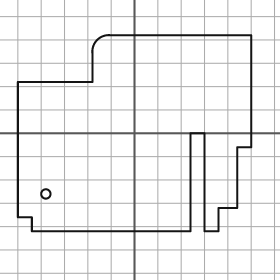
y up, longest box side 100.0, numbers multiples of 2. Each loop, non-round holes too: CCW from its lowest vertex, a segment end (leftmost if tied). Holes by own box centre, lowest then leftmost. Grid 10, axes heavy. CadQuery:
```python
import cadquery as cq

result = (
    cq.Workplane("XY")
    .moveTo(-44.0, -42.0)
    .lineTo(24.0, -42.0)
    .lineTo(24.0, 0.0)
    .lineTo(30.0, 0.0)
    .lineTo(30.0, -42.0)
    .lineTo(36.0, -42.0)
    .lineTo(36.0, -32.0)
    .lineTo(44.0, -32.0)
    .lineTo(44.0, -6.0)
    .lineTo(50.0, -6.0)
    .lineTo(50.0, 42.0)
    .lineTo(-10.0, 42.0)
    .threePointArc((-16.0, 40.0), (-18.0, 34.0))
    .lineTo(-18.0, 22.0)
    .lineTo(-50.0, 22.0)
    .lineTo(-50.0, -36.0)
    .lineTo(-44.0, -36.0)
    .close()
    .moveTo(-38.0, -26.0)
    .circle(2.0)
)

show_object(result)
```